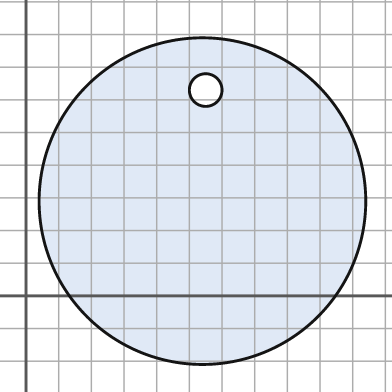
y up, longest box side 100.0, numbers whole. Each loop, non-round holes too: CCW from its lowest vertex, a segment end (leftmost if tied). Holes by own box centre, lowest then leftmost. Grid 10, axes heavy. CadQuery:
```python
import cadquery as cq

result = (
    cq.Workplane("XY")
    .moveTo(54.0, 29.0)
    .circle(50.0)
    .moveTo(55.0, 63.0)
    .circle(5.0)
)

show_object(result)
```